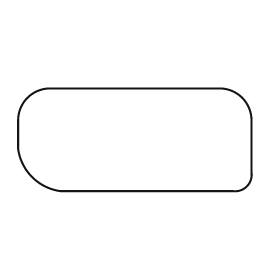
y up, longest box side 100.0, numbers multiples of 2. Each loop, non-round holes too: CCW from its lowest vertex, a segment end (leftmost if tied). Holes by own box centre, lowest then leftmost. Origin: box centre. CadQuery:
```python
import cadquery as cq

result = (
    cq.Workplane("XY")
    .moveTo(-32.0, -22.0)
    .lineTo(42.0, -22.0)
    .threePointArc((48.0, -20.0), (50.0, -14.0))
    .lineTo(50.0, 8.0)
    .threePointArc((46.0, 18.0), (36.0, 22.0))
    .lineTo(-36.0, 22.0)
    .threePointArc((-46.0, 18.0), (-50.0, 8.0))
    .lineTo(-50.0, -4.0)
    .threePointArc((-44.0, -16.0), (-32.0, -22.0))
    .close()
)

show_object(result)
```